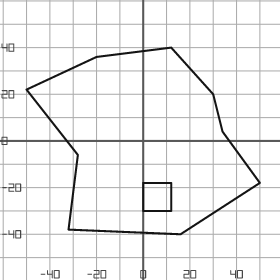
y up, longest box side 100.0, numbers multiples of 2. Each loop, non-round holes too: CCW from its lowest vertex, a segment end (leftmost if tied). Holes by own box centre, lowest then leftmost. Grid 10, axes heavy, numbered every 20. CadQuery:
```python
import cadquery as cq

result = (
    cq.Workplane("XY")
    .moveTo(16.0, -40.0)
    .lineTo(50.0, -18.0)
    .lineTo(34.0, 4.0)
    .lineTo(30.0, 20.0)
    .lineTo(12.0, 40.0)
    .lineTo(-20.0, 36.0)
    .lineTo(-50.0, 22.0)
    .lineTo(-28.0, -6.0)
    .lineTo(-32.0, -38.0)
    .close()
    .moveTo(0.0, -30.0)
    .lineTo(12.0, -30.0)
    .lineTo(12.0, -18.0)
    .lineTo(0.0, -18.0)
    .close()
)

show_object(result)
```